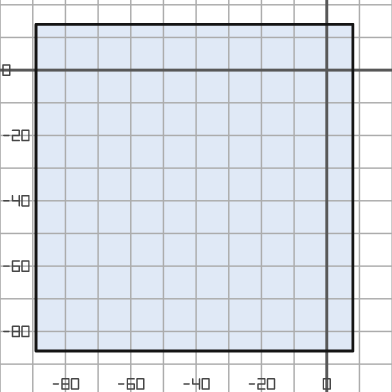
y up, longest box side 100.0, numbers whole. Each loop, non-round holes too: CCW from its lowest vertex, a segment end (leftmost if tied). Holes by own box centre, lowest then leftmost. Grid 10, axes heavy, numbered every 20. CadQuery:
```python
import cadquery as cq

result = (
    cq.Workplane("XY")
    .moveTo(-89.0, -86.0)
    .lineTo(8.0, -86.0)
    .lineTo(8.0, 14.0)
    .lineTo(-89.0, 14.0)
    .close()
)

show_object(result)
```